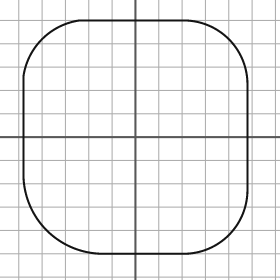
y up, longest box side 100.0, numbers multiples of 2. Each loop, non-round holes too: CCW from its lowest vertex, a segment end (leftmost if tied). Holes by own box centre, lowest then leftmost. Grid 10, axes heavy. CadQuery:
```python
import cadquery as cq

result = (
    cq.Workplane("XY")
    .moveTo(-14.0, -50.0)
    .lineTo(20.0, -50.0)
    .threePointArc((40.0, -42.0), (48.0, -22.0))
    .lineTo(48.0, 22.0)
    .threePointArc((40.0, 42.0), (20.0, 50.0))
    .lineTo(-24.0, 50.0)
    .threePointArc((-40.0, 42.0), (-48.0, 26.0))
    .lineTo(-48.0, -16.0)
    .threePointArc((-38.0, -40.0), (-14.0, -50.0))
    .close()
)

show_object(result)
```